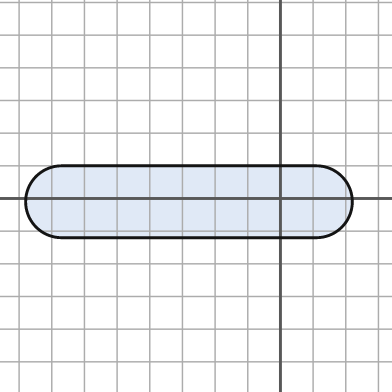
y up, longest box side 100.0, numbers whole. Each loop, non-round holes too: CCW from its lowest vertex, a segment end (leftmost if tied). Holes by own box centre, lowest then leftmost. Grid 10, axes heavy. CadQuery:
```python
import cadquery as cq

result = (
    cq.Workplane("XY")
    .moveTo(-67.0, -12.0)
    .lineTo(11.0, -12.0)
    .threePointArc((22.0, -1.0), (11.0, 10.0))
    .lineTo(-67.0, 10.0)
    .threePointArc((-78.0, -1.0), (-67.0, -12.0))
    .close()
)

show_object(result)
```